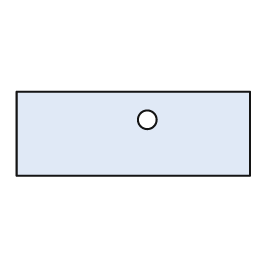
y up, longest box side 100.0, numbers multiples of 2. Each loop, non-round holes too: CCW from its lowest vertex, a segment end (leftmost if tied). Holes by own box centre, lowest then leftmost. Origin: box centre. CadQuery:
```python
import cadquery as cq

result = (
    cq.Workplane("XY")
    .moveTo(-50.0, -18.0)
    .lineTo(50.0, -18.0)
    .lineTo(50.0, 18.0)
    .lineTo(-50.0, 18.0)
    .close()
    .moveTo(6.0, 6.0)
    .circle(4.0)
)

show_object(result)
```